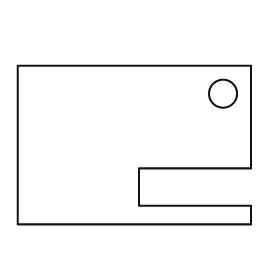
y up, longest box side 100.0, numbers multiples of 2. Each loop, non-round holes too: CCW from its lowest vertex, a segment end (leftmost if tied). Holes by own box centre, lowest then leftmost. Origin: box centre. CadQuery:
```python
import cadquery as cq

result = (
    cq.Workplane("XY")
    .moveTo(-50.0, -34.0)
    .lineTo(50.0, -34.0)
    .lineTo(50.0, -26.0)
    .lineTo(2.0, -26.0)
    .lineTo(2.0, -10.0)
    .lineTo(50.0, -10.0)
    .lineTo(50.0, 34.0)
    .lineTo(-50.0, 34.0)
    .close()
    .moveTo(38.0, 22.0)
    .circle(6.0)
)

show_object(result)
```